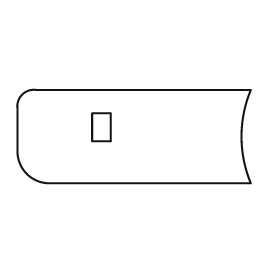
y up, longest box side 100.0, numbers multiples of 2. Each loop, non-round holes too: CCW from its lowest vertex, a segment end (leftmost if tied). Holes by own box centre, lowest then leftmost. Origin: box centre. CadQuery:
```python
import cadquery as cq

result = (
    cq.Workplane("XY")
    .moveTo(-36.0, -20.0)
    .lineTo(50.0, -20.0)
    .threePointArc((46.0, 0.0), (50.0, 20.0))
    .lineTo(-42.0, 20.0)
    .threePointArc((-48.0, 18.0), (-50.0, 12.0))
    .lineTo(-50.0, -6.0)
    .threePointArc((-46.0, -16.0), (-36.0, -20.0))
    .close()
    .moveTo(-18.0, -2.0)
    .lineTo(-10.0, -2.0)
    .lineTo(-10.0, 10.0)
    .lineTo(-18.0, 10.0)
    .close()
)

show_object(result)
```